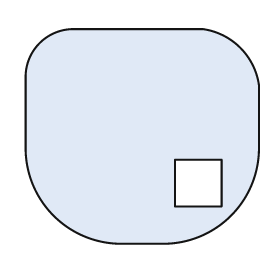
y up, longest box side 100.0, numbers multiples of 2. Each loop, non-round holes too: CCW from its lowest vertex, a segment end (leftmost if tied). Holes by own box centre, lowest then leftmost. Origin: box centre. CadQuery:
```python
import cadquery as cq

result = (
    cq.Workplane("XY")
    .moveTo(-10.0, -46.0)
    .lineTo(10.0, -46.0)
    .threePointArc((38.0, -34.0), (50.0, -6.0))
    .lineTo(50.0, 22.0)
    .threePointArc((42.0, 38.0), (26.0, 46.0))
    .lineTo(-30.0, 46.0)
    .threePointArc((-44.0, 40.0), (-50.0, 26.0))
    .lineTo(-50.0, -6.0)
    .threePointArc((-38.0, -34.0), (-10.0, -46.0))
    .close()
    .moveTo(14.0, -30.0)
    .lineTo(34.0, -30.0)
    .lineTo(34.0, -10.0)
    .lineTo(14.0, -10.0)
    .close()
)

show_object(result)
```